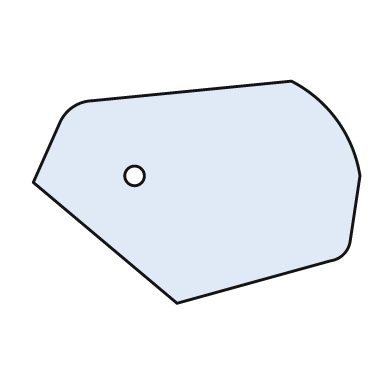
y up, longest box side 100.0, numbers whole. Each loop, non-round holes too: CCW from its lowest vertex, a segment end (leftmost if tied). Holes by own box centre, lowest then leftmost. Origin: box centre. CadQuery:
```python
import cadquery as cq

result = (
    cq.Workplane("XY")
    .moveTo(-6.0, -34.0)
    .lineTo(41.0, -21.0)
    .threePointArc((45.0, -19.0), (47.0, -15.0))
    .lineTo(50.0, 5.0)
    .threePointArc((43.0, 22.0), (29.0, 34.0))
    .lineTo(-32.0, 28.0)
    .threePointArc((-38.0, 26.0), (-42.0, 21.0))
    .lineTo(-50.0, 3.0)
    .close()
    .moveTo(-19.0, 5.0)
    .circle(3.0)
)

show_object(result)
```